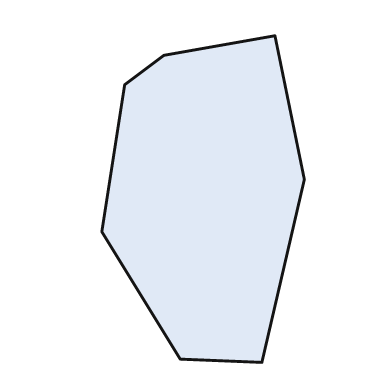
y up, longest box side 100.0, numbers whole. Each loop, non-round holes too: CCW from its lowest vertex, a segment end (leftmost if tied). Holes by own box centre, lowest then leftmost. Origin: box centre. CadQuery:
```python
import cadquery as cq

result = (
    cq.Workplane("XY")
    .moveTo(18.0, -50.0)
    .lineTo(31.0, 6.0)
    .lineTo(22.0, 50.0)
    .lineTo(-12.0, 44.0)
    .lineTo(-24.0, 35.0)
    .lineTo(-31.0, -10.0)
    .lineTo(-7.0, -49.0)
    .close()
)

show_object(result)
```